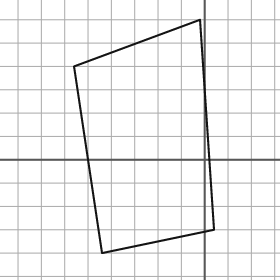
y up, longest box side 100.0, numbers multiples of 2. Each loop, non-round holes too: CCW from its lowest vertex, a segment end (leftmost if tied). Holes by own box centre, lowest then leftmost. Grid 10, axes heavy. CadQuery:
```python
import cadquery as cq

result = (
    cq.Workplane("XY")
    .moveTo(-44.0, -40.0)
    .lineTo(4.0, -30.0)
    .lineTo(-2.0, 60.0)
    .lineTo(-56.0, 40.0)
    .close()
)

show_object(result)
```